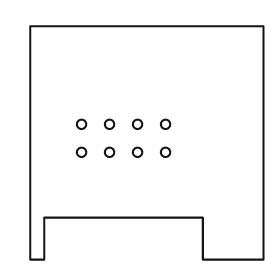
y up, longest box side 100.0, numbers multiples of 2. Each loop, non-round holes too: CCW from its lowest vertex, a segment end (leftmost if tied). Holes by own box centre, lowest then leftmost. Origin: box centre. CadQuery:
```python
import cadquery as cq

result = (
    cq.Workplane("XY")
    .moveTo(-50.0, -50.0)
    .lineTo(-44.0, -50.0)
    .lineTo(-44.0, -32.0)
    .lineTo(24.0, -32.0)
    .lineTo(24.0, -50.0)
    .lineTo(50.0, -50.0)
    .lineTo(50.0, 50.0)
    .lineTo(-50.0, 50.0)
    .close()
    .moveTo(-28.0, -4.0)
    .circle(2.0)
    .moveTo(-16.0, -4.0)
    .circle(2.0)
    .moveTo(-4.0, -4.0)
    .circle(2.0)
    .moveTo(8.0, -4.0)
    .circle(2.0)
    .moveTo(-28.0, 8.0)
    .circle(2.0)
    .moveTo(-16.0, 8.0)
    .circle(2.0)
    .moveTo(-4.0, 8.0)
    .circle(2.0)
    .moveTo(8.0, 8.0)
    .circle(2.0)
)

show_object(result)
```